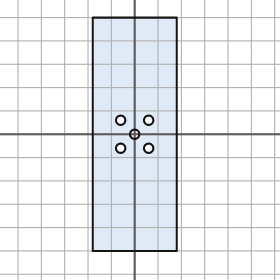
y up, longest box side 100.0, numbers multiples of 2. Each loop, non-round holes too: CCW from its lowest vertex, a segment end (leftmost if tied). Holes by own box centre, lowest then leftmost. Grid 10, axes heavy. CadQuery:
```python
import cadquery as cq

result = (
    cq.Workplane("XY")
    .moveTo(-18.0, -50.0)
    .lineTo(18.0, -50.0)
    .lineTo(18.0, 50.0)
    .lineTo(-18.0, 50.0)
    .close()
    .moveTo(-6.0, -6.0)
    .circle(2.0)
    .moveTo(6.0, -6.0)
    .circle(2.0)
    .moveTo(0.0, 0.0)
    .circle(2.0)
    .moveTo(-6.0, 6.0)
    .circle(2.0)
    .moveTo(6.0, 6.0)
    .circle(2.0)
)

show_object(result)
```